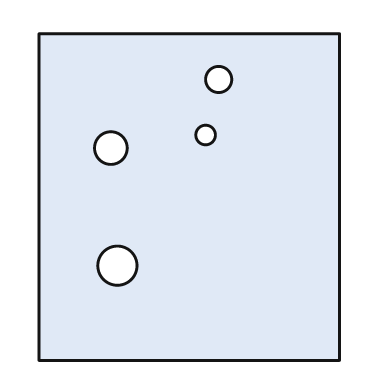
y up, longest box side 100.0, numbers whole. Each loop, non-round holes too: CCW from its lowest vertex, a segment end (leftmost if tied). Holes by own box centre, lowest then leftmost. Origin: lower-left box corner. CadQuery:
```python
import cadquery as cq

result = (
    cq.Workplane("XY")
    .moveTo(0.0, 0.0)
    .lineTo(92.0, 0.0)
    .lineTo(92.0, 100.0)
    .lineTo(0.0, 100.0)
    .close()
    .moveTo(24.0, 29.0)
    .circle(6.0)
    .moveTo(22.0, 65.0)
    .circle(5.0)
    .moveTo(51.0, 69.0)
    .circle(3.0)
    .moveTo(55.0, 86.0)
    .circle(4.0)
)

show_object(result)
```